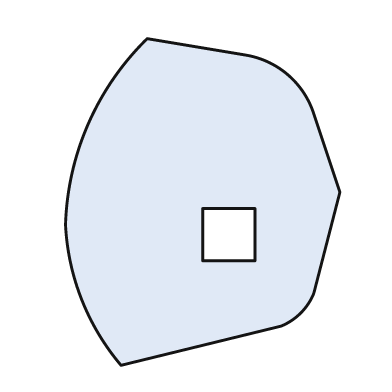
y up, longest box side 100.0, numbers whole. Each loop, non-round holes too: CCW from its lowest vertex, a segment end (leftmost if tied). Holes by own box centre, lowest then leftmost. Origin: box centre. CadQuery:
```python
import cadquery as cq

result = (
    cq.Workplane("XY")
    .moveTo(-25.0, -50.0)
    .lineTo(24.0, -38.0)
    .threePointArc((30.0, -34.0), (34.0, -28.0))
    .lineTo(42.0, 3.0)
    .lineTo(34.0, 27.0)
    .threePointArc((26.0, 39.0), (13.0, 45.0))
    .lineTo(-17.0, 50.0)
    .threePointArc((-35.0, 24.0), (-42.0, -7.0))
    .threePointArc((-37.0, -30.0), (-25.0, -50.0))
    .close()
    .moveTo(0.0, -18.0)
    .lineTo(16.0, -18.0)
    .lineTo(16.0, -2.0)
    .lineTo(0.0, -2.0)
    .close()
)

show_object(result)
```